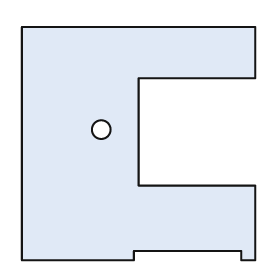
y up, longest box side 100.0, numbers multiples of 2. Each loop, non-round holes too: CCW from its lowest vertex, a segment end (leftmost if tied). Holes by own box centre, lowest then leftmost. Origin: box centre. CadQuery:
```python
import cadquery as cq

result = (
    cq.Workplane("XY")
    .moveTo(-50.0, -50.0)
    .lineTo(-2.0, -50.0)
    .lineTo(-2.0, -46.0)
    .lineTo(44.0, -46.0)
    .lineTo(44.0, -50.0)
    .lineTo(50.0, -50.0)
    .lineTo(50.0, -18.0)
    .lineTo(0.0, -18.0)
    .lineTo(0.0, 28.0)
    .lineTo(50.0, 28.0)
    .lineTo(50.0, 50.0)
    .lineTo(-50.0, 50.0)
    .close()
    .moveTo(-16.0, 6.0)
    .circle(4.0)
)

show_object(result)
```